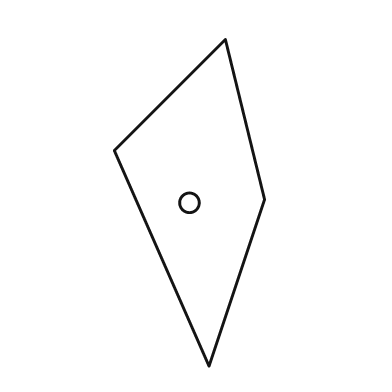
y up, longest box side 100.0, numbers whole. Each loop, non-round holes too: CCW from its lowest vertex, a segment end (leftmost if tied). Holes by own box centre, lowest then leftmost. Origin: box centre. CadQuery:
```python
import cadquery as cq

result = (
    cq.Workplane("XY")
    .moveTo(6.0, -50.0)
    .lineTo(23.0, 1.0)
    .lineTo(11.0, 50.0)
    .lineTo(-23.0, 16.0)
    .close()
    .moveTo(0.0, 0.0)
    .circle(3.0)
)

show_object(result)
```